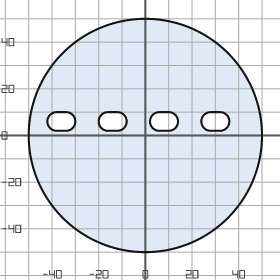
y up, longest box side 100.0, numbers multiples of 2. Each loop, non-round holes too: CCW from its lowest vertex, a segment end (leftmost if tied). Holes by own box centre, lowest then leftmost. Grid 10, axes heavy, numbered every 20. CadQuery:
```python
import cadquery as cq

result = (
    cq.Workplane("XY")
    .moveTo(0.0, 0.0)
    .circle(50.0)
    .moveTo(-38.0, 2.0)
    .lineTo(-34.0, 2.0)
    .threePointArc((-30.0, 6.0), (-34.0, 10.0))
    .lineTo(-38.0, 10.0)
    .threePointArc((-42.0, 6.0), (-38.0, 2.0))
    .close()
    .moveTo(-16.0, 2.0)
    .lineTo(-12.0, 2.0)
    .threePointArc((-8.0, 6.0), (-12.0, 10.0))
    .lineTo(-16.0, 10.0)
    .threePointArc((-20.0, 6.0), (-16.0, 2.0))
    .close()
    .moveTo(6.0, 2.0)
    .lineTo(10.0, 2.0)
    .threePointArc((14.0, 6.0), (10.0, 10.0))
    .lineTo(6.0, 10.0)
    .threePointArc((2.0, 6.0), (6.0, 2.0))
    .close()
    .moveTo(28.0, 2.0)
    .lineTo(32.0, 2.0)
    .threePointArc((36.0, 6.0), (32.0, 10.0))
    .lineTo(28.0, 10.0)
    .threePointArc((24.0, 6.0), (28.0, 2.0))
    .close()
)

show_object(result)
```